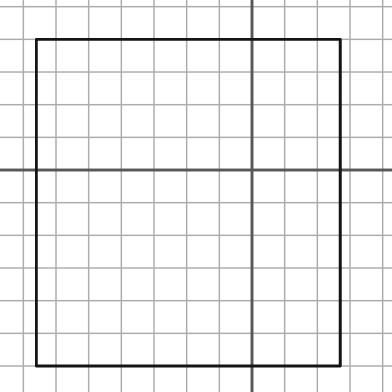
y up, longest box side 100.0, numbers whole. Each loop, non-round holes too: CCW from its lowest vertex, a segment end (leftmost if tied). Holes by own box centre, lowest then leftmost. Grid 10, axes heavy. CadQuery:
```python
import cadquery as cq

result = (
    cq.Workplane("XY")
    .moveTo(-66.0, -60.0)
    .lineTo(27.0, -60.0)
    .lineTo(27.0, 40.0)
    .lineTo(-66.0, 40.0)
    .close()
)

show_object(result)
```